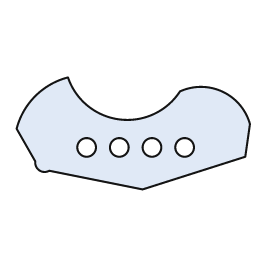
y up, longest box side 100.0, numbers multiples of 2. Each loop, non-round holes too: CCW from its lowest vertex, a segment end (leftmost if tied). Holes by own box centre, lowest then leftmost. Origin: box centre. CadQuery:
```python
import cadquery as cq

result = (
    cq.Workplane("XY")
    .moveTo(4.0, -24.0)
    .lineTo(48.0, -10.0)
    .lineTo(50.0, 4.0)
    .threePointArc((38.0, 18.0), (20.0, 18.0))
    .threePointArc((-6.0, 6.0), (-28.0, 24.0))
    .threePointArc((-42.0, 16.0), (-50.0, 2.0))
    .lineTo(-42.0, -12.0)
    .threePointArc((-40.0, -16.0), (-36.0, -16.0))
    .close()
    .moveTo(-20.0, -6.0)
    .circle(4.0)
    .moveTo(-6.0, -6.0)
    .circle(4.0)
    .moveTo(8.0, -6.0)
    .circle(4.0)
    .moveTo(22.0, -6.0)
    .circle(4.0)
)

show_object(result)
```